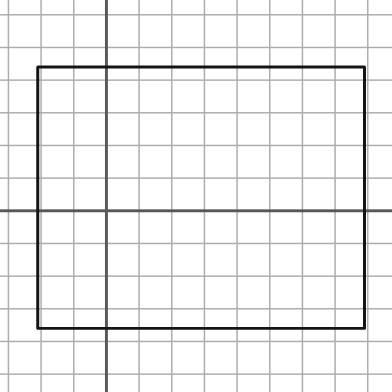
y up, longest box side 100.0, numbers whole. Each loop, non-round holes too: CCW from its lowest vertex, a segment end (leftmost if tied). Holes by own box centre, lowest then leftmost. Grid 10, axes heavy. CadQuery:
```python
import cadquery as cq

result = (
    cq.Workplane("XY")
    .moveTo(-21.0, -36.0)
    .lineTo(79.0, -36.0)
    .lineTo(79.0, 44.0)
    .lineTo(-21.0, 44.0)
    .close()
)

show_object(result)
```